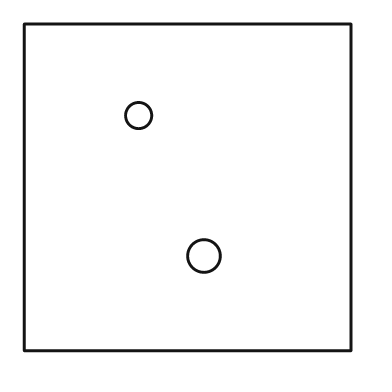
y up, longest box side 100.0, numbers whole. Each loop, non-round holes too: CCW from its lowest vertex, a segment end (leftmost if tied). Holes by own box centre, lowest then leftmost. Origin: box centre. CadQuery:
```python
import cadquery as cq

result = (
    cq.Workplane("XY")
    .moveTo(-50.0, -50.0)
    .lineTo(50.0, -50.0)
    .lineTo(50.0, 50.0)
    .lineTo(-50.0, 50.0)
    .close()
    .moveTo(5.0, -21.0)
    .circle(5.0)
    .moveTo(-15.0, 22.0)
    .circle(4.0)
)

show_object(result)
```